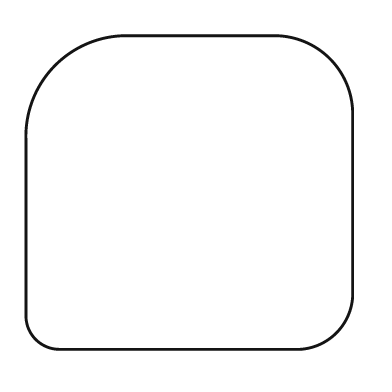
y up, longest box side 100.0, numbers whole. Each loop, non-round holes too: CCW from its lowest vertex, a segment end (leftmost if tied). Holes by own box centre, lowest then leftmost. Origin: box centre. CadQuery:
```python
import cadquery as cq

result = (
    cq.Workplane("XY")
    .moveTo(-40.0, -48.0)
    .lineTo(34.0, -48.0)
    .threePointArc((45.0, -43.0), (50.0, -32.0))
    .lineTo(50.0, 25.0)
    .threePointArc((43.0, 41.0), (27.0, 48.0))
    .lineTo(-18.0, 48.0)
    .threePointArc((-41.0, 39.0), (-50.0, 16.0))
    .lineTo(-50.0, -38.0)
    .threePointArc((-47.0, -45.0), (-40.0, -48.0))
    .close()
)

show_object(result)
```